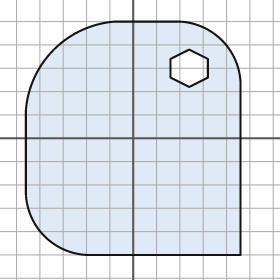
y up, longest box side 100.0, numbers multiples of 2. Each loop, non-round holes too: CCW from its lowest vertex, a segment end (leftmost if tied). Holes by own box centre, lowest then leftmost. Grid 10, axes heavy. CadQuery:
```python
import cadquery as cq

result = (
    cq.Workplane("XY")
    .moveTo(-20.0, -50.0)
    .lineTo(46.0, -50.0)
    .lineTo(46.0, 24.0)
    .threePointArc((38.0, 42.0), (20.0, 50.0))
    .lineTo(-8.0, 50.0)
    .threePointArc((-34.0, 38.0), (-46.0, 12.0))
    .lineTo(-46.0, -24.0)
    .threePointArc((-38.0, -42.0), (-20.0, -50.0))
    .close()
    .moveTo(24.0, 22.0)
    .lineTo(32.0, 26.0)
    .lineTo(32.0, 34.0)
    .lineTo(24.0, 38.0)
    .lineTo(16.0, 34.0)
    .lineTo(16.0, 26.0)
    .close()
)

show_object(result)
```